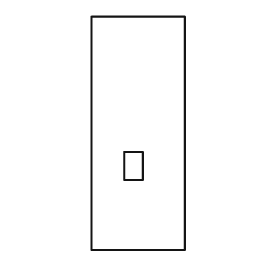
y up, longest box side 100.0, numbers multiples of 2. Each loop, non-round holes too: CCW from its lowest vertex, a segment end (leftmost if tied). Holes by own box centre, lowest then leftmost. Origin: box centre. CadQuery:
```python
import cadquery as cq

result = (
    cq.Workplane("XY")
    .moveTo(-20.0, -50.0)
    .lineTo(20.0, -50.0)
    .lineTo(20.0, 50.0)
    .lineTo(-20.0, 50.0)
    .close()
    .moveTo(-6.0, -20.0)
    .lineTo(2.0, -20.0)
    .lineTo(2.0, -8.0)
    .lineTo(-6.0, -8.0)
    .close()
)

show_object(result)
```